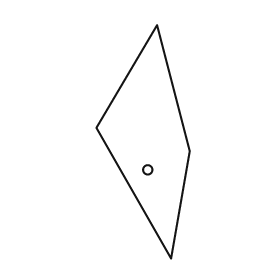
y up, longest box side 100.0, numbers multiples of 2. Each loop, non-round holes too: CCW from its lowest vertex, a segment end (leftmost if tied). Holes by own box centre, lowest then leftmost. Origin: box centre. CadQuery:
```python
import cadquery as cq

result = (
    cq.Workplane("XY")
    .moveTo(12.0, -50.0)
    .lineTo(20.0, -4.0)
    .lineTo(6.0, 50.0)
    .lineTo(-20.0, 6.0)
    .close()
    .moveTo(2.0, -12.0)
    .circle(2.0)
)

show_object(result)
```